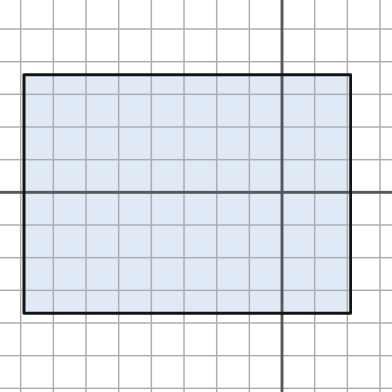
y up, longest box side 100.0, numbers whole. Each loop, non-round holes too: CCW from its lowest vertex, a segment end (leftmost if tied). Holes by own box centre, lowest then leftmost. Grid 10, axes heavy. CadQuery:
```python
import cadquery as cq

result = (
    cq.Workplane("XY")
    .moveTo(-79.0, -37.0)
    .lineTo(21.0, -37.0)
    .lineTo(21.0, 36.0)
    .lineTo(-79.0, 36.0)
    .close()
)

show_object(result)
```